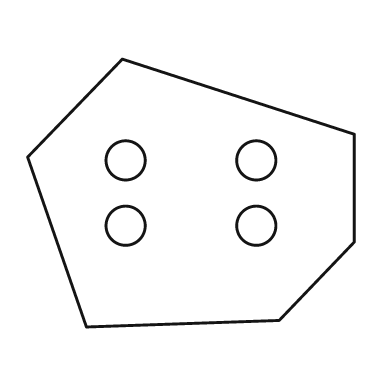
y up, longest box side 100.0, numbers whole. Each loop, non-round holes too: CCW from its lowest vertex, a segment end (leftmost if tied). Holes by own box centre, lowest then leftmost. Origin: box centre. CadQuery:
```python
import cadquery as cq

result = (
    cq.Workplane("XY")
    .moveTo(-32.0, -41.0)
    .lineTo(27.0, -39.0)
    .lineTo(50.0, -15.0)
    .lineTo(50.0, 18.0)
    .lineTo(-21.0, 41.0)
    .lineTo(-50.0, 11.0)
    .close()
    .moveTo(-20.0, -10.0)
    .circle(6.0)
    .moveTo(20.0, -10.0)
    .circle(6.0)
    .moveTo(-20.0, 10.0)
    .circle(6.0)
    .moveTo(20.0, 10.0)
    .circle(6.0)
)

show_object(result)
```